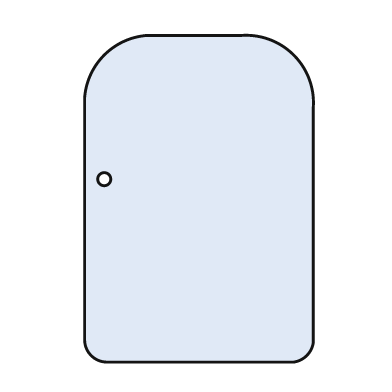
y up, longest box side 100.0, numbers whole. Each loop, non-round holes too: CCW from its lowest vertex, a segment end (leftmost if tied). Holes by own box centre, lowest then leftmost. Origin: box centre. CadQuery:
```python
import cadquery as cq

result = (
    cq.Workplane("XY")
    .moveTo(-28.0, -50.0)
    .lineTo(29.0, -50.0)
    .threePointArc((33.0, -48.0), (35.0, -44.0))
    .lineTo(35.0, 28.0)
    .threePointArc((29.0, 44.0), (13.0, 50.0))
    .lineTo(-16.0, 50.0)
    .threePointArc((-29.0, 44.0), (-35.0, 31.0))
    .lineTo(-35.0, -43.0)
    .threePointArc((-33.0, -48.0), (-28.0, -50.0))
    .close()
    .moveTo(-29.0, 6.0)
    .circle(2.0)
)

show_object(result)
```